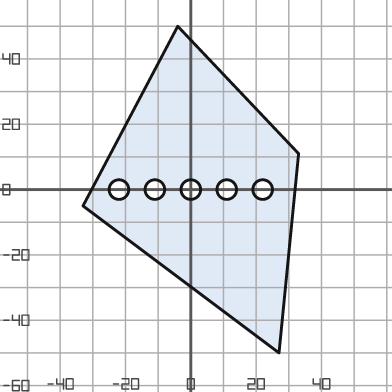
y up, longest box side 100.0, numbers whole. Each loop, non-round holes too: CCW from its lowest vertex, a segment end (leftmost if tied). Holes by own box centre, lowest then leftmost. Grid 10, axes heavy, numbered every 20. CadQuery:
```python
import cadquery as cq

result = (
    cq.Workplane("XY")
    .moveTo(27.0, -50.0)
    .lineTo(33.0, 11.0)
    .lineTo(-4.0, 50.0)
    .lineTo(-33.0, -5.0)
    .close()
    .moveTo(-22.0, 0.0)
    .circle(3.0)
    .moveTo(-11.0, 0.0)
    .circle(3.0)
    .moveTo(0.0, 0.0)
    .circle(3.0)
    .moveTo(11.0, 0.0)
    .circle(3.0)
    .moveTo(22.0, 0.0)
    .circle(3.0)
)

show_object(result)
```